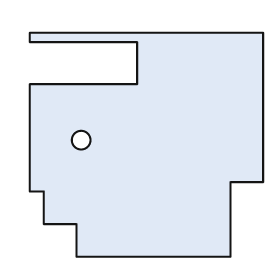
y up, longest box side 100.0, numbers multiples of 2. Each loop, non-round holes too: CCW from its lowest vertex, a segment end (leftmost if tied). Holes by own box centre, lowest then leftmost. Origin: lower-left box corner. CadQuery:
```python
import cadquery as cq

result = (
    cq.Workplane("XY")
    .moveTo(20.0, 0.0)
    .lineTo(86.0, 0.0)
    .lineTo(86.0, 32.0)
    .lineTo(100.0, 32.0)
    .lineTo(100.0, 96.0)
    .lineTo(0.0, 96.0)
    .lineTo(0.0, 92.0)
    .lineTo(46.0, 92.0)
    .lineTo(46.0, 74.0)
    .lineTo(0.0, 74.0)
    .lineTo(0.0, 28.0)
    .lineTo(6.0, 28.0)
    .lineTo(6.0, 14.0)
    .lineTo(20.0, 14.0)
    .close()
    .moveTo(22.0, 50.0)
    .circle(4.0)
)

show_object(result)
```